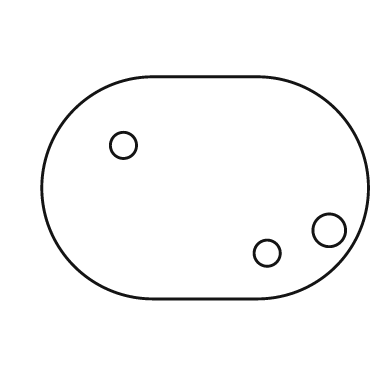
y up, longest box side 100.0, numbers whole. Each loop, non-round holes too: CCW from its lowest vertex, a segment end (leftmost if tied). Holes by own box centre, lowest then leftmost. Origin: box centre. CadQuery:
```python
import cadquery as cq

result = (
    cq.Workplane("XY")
    .moveTo(-16.0, -34.0)
    .lineTo(16.0, -34.0)
    .threePointArc((50.0, 0.0), (16.0, 34.0))
    .lineTo(-16.0, 34.0)
    .threePointArc((-50.0, 0.0), (-16.0, -34.0))
    .close()
    .moveTo(19.0, -20.0)
    .circle(4.0)
    .moveTo(38.0, -13.0)
    .circle(5.0)
    .moveTo(-25.0, 13.0)
    .circle(4.0)
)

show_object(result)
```